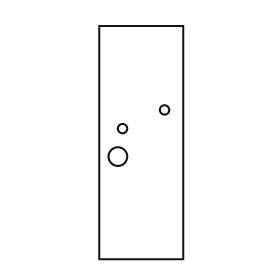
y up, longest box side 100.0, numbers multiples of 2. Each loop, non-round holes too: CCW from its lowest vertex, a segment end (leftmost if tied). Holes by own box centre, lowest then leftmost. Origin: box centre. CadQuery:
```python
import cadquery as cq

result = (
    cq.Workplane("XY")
    .moveTo(-18.0, -50.0)
    .lineTo(18.0, -50.0)
    .lineTo(18.0, 50.0)
    .lineTo(-18.0, 50.0)
    .close()
    .moveTo(-10.0, -6.0)
    .circle(4.0)
    .moveTo(-8.0, 6.0)
    .circle(2.0)
    .moveTo(10.0, 14.0)
    .circle(2.0)
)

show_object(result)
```